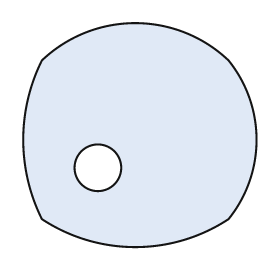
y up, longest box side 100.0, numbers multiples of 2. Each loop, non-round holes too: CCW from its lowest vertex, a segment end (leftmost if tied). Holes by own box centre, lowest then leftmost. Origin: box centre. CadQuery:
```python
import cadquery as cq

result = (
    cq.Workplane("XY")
    .moveTo(-42.0, -36.0)
    .threePointArc((-2.0, -48.0), (38.0, -36.0))
    .threePointArc((50.0, -2.0), (38.0, 32.0))
    .threePointArc((-2.0, 48.0), (-42.0, 32.0))
    .threePointArc((-50.0, -2.0), (-42.0, -36.0))
    .close()
    .moveTo(-18.0, -14.0)
    .circle(10.0)
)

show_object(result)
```